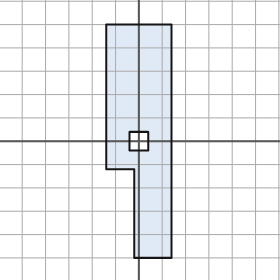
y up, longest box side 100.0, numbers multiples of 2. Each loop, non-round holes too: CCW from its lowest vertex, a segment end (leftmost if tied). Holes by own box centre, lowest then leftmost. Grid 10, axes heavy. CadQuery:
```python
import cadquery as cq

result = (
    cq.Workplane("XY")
    .moveTo(-2.0, -50.0)
    .lineTo(14.0, -50.0)
    .lineTo(14.0, 50.0)
    .lineTo(-14.0, 50.0)
    .lineTo(-14.0, -12.0)
    .lineTo(-2.0, -12.0)
    .close()
    .moveTo(-4.0, -4.0)
    .lineTo(4.0, -4.0)
    .lineTo(4.0, 4.0)
    .lineTo(-4.0, 4.0)
    .close()
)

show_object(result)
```